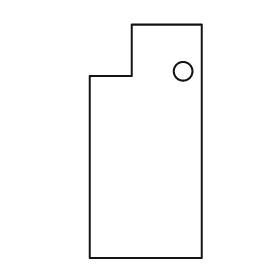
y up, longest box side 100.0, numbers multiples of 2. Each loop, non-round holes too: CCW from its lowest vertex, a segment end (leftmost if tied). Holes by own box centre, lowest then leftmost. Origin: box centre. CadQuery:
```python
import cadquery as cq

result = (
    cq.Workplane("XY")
    .moveTo(-24.0, -50.0)
    .lineTo(24.0, -50.0)
    .lineTo(24.0, 50.0)
    .lineTo(-6.0, 50.0)
    .lineTo(-6.0, 28.0)
    .lineTo(-24.0, 28.0)
    .close()
    .moveTo(16.0, 30.0)
    .circle(4.0)
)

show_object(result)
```